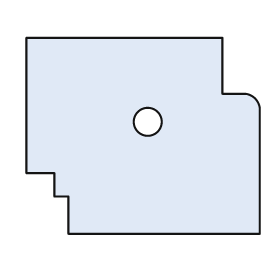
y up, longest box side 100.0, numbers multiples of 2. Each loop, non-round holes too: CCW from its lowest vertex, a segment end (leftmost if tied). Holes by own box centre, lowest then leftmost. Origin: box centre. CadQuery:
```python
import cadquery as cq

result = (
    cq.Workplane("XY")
    .moveTo(-32.0, -42.0)
    .lineTo(50.0, -42.0)
    .lineTo(50.0, 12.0)
    .threePointArc((48.0, 16.0), (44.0, 18.0))
    .lineTo(34.0, 18.0)
    .lineTo(34.0, 42.0)
    .lineTo(-50.0, 42.0)
    .lineTo(-50.0, -16.0)
    .lineTo(-38.0, -16.0)
    .lineTo(-38.0, -26.0)
    .lineTo(-32.0, -26.0)
    .close()
    .moveTo(2.0, 6.0)
    .circle(6.0)
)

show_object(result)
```